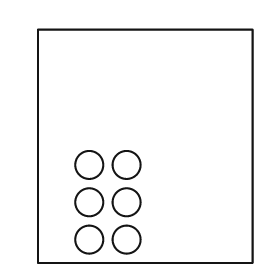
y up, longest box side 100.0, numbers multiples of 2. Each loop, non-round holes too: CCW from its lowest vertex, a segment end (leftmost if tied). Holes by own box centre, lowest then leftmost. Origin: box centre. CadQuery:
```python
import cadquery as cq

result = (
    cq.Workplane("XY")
    .moveTo(-46.0, -50.0)
    .lineTo(46.0, -50.0)
    .lineTo(46.0, 50.0)
    .lineTo(-46.0, 50.0)
    .close()
    .moveTo(-24.0, -40.0)
    .circle(6.0)
    .moveTo(-8.0, -40.0)
    .circle(6.0)
    .moveTo(-24.0, -24.0)
    .circle(6.0)
    .moveTo(-8.0, -24.0)
    .circle(6.0)
    .moveTo(-24.0, -8.0)
    .circle(6.0)
    .moveTo(-8.0, -8.0)
    .circle(6.0)
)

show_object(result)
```